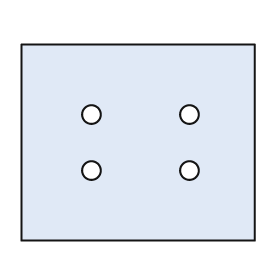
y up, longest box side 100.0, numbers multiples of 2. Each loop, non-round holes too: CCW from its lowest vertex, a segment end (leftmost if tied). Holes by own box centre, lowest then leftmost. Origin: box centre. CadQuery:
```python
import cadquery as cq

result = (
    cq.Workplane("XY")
    .moveTo(-50.0, -42.0)
    .lineTo(50.0, -42.0)
    .lineTo(50.0, 42.0)
    .lineTo(-50.0, 42.0)
    .close()
    .moveTo(-20.0, -12.0)
    .circle(4.0)
    .moveTo(22.0, -12.0)
    .circle(4.0)
    .moveTo(-20.0, 12.0)
    .circle(4.0)
    .moveTo(22.0, 12.0)
    .circle(4.0)
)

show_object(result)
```